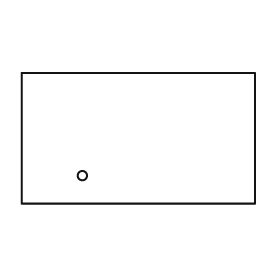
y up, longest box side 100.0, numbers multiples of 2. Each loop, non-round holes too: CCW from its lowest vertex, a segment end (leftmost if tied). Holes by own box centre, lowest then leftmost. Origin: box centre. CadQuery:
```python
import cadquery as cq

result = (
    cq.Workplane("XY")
    .moveTo(-50.0, -28.0)
    .lineTo(50.0, -28.0)
    .lineTo(50.0, 28.0)
    .lineTo(-50.0, 28.0)
    .close()
    .moveTo(-24.0, -16.0)
    .circle(2.0)
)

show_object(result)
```